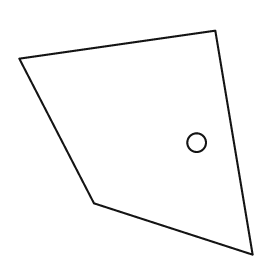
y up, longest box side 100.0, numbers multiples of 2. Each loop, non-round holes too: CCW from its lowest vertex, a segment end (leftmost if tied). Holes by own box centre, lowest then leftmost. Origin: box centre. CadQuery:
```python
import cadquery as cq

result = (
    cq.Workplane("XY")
    .moveTo(50.0, -48.0)
    .lineTo(34.0, 48.0)
    .lineTo(-50.0, 36.0)
    .lineTo(-18.0, -26.0)
    .close()
    .moveTo(26.0, 0.0)
    .circle(4.0)
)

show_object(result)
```